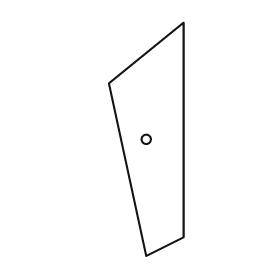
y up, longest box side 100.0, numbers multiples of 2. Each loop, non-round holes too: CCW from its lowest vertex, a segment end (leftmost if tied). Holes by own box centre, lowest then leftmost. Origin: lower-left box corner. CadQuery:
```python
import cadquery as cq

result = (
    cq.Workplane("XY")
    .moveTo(16.0, 0.0)
    .lineTo(32.0, 8.0)
    .lineTo(32.0, 100.0)
    .lineTo(0.0, 74.0)
    .close()
    .moveTo(16.0, 50.0)
    .circle(2.0)
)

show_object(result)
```